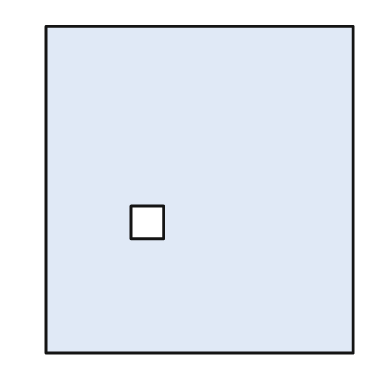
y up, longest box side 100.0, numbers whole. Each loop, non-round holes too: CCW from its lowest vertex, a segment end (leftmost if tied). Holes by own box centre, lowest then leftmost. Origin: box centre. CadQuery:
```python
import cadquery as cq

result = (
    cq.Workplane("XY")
    .moveTo(-47.0, -50.0)
    .lineTo(47.0, -50.0)
    .lineTo(47.0, 50.0)
    .lineTo(-47.0, 50.0)
    .close()
    .moveTo(-21.0, -15.0)
    .lineTo(-11.0, -15.0)
    .lineTo(-11.0, -5.0)
    .lineTo(-21.0, -5.0)
    .close()
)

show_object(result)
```